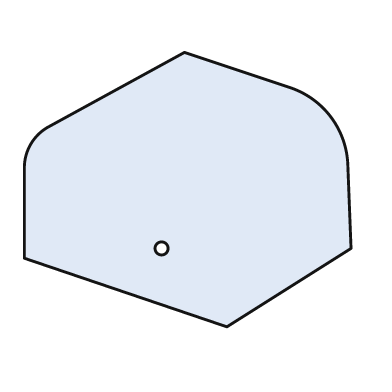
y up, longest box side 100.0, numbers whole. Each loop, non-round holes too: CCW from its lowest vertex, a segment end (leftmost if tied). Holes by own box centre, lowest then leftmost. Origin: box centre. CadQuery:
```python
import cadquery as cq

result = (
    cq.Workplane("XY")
    .moveTo(12.0, -42.0)
    .lineTo(50.0, -18.0)
    .lineTo(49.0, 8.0)
    .threePointArc((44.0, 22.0), (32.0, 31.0))
    .lineTo(-1.0, 42.0)
    .lineTo(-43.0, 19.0)
    .threePointArc((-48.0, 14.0), (-50.0, 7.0))
    .lineTo(-50.0, -21.0)
    .close()
    .moveTo(-8.0, -18.0)
    .circle(2.0)
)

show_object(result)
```